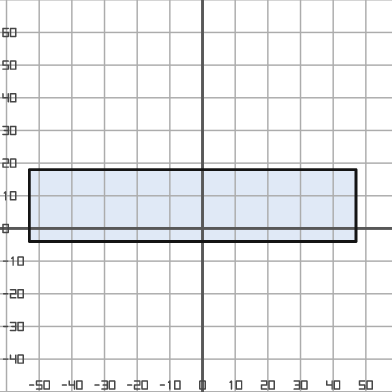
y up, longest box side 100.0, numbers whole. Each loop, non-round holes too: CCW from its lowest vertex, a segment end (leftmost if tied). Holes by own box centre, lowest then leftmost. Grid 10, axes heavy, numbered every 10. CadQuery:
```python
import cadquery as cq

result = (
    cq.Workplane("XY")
    .moveTo(-53.0, -4.0)
    .lineTo(47.0, -4.0)
    .lineTo(47.0, 18.0)
    .lineTo(-53.0, 18.0)
    .close()
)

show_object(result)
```